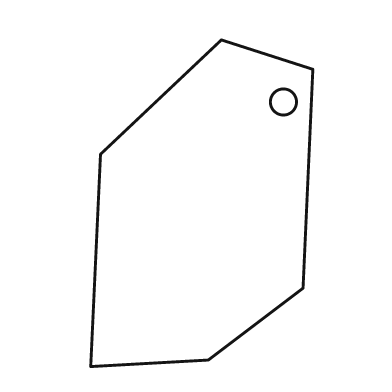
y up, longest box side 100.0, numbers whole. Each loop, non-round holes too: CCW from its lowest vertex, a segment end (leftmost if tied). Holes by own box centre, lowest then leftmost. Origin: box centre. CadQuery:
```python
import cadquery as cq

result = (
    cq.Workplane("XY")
    .moveTo(-34.0, -50.0)
    .lineTo(2.0, -48.0)
    .lineTo(31.0, -26.0)
    .lineTo(34.0, 41.0)
    .lineTo(6.0, 50.0)
    .lineTo(-31.0, 15.0)
    .close()
    .moveTo(25.0, 31.0)
    .circle(4.0)
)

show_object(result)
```